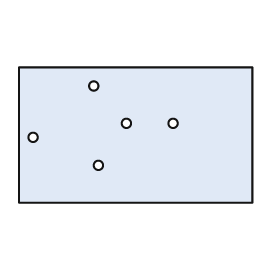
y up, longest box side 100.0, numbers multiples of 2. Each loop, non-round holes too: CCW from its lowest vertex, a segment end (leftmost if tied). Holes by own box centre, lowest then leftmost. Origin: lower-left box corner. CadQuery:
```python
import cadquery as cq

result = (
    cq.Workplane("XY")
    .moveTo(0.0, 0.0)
    .lineTo(100.0, 0.0)
    .lineTo(100.0, 58.0)
    .lineTo(0.0, 58.0)
    .close()
    .moveTo(34.0, 16.0)
    .circle(2.0)
    .moveTo(6.0, 28.0)
    .circle(2.0)
    .moveTo(46.0, 34.0)
    .circle(2.0)
    .moveTo(66.0, 34.0)
    .circle(2.0)
    .moveTo(32.0, 50.0)
    .circle(2.0)
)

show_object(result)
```